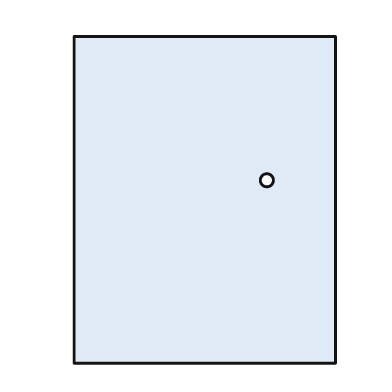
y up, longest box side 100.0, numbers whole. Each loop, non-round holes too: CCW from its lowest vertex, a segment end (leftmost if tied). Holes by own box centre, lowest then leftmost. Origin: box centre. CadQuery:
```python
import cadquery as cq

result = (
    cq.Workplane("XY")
    .moveTo(-40.0, -50.0)
    .lineTo(40.0, -50.0)
    .lineTo(40.0, 50.0)
    .lineTo(-40.0, 50.0)
    .close()
    .moveTo(19.0, 6.0)
    .circle(2.0)
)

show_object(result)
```